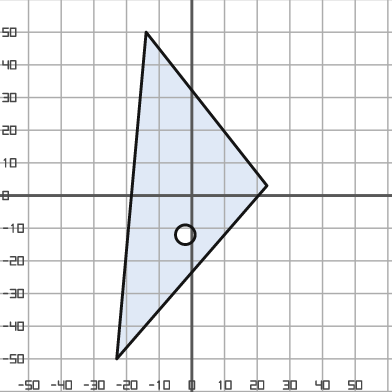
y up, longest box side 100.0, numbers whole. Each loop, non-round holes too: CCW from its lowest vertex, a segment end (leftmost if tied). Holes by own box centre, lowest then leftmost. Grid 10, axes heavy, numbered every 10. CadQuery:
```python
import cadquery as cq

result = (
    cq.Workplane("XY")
    .moveTo(-23.0, -50.0)
    .lineTo(23.0, 3.0)
    .lineTo(-14.0, 50.0)
    .close()
    .moveTo(-2.0, -12.0)
    .circle(3.0)
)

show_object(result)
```